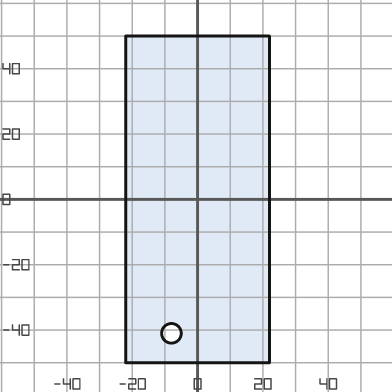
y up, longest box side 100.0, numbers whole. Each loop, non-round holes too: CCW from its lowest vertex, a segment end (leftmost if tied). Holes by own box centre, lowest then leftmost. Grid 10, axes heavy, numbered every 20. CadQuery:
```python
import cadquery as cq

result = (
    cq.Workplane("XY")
    .moveTo(-22.0, -50.0)
    .lineTo(22.0, -50.0)
    .lineTo(22.0, 50.0)
    .lineTo(-22.0, 50.0)
    .close()
    .moveTo(-8.0, -41.0)
    .circle(3.0)
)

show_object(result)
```